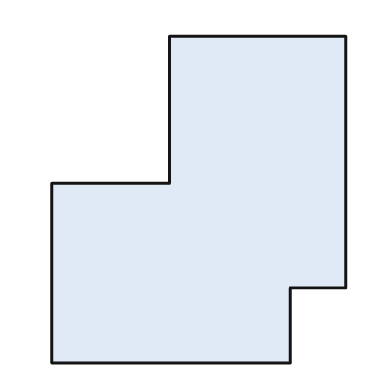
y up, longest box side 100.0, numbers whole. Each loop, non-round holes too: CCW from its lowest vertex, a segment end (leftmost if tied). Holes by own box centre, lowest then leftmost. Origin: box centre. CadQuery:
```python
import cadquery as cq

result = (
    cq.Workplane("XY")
    .moveTo(-45.0, -50.0)
    .lineTo(28.0, -50.0)
    .lineTo(28.0, -27.0)
    .lineTo(45.0, -27.0)
    .lineTo(45.0, 50.0)
    .lineTo(-9.0, 50.0)
    .lineTo(-9.0, 5.0)
    .lineTo(-45.0, 5.0)
    .close()
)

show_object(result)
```